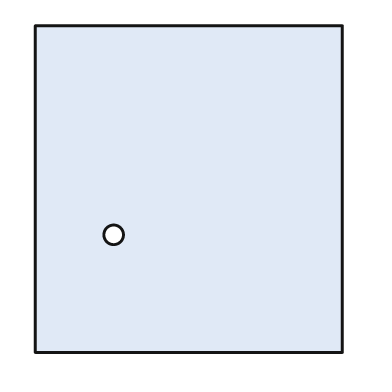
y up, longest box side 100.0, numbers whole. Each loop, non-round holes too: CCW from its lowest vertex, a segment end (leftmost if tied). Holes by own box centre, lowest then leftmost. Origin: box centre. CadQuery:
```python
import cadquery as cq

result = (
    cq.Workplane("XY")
    .moveTo(-47.0, -50.0)
    .lineTo(47.0, -50.0)
    .lineTo(47.0, 50.0)
    .lineTo(-47.0, 50.0)
    .close()
    .moveTo(-23.0, -14.0)
    .circle(3.0)
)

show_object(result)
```